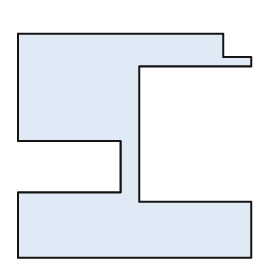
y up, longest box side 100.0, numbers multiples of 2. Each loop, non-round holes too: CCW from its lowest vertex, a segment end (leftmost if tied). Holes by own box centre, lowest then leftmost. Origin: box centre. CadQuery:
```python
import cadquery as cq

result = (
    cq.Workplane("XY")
    .moveTo(-50.0, -48.0)
    .lineTo(50.0, -48.0)
    .lineTo(50.0, -24.0)
    .lineTo(2.0, -24.0)
    .lineTo(2.0, 34.0)
    .lineTo(50.0, 34.0)
    .lineTo(50.0, 38.0)
    .lineTo(38.0, 38.0)
    .lineTo(38.0, 48.0)
    .lineTo(-50.0, 48.0)
    .lineTo(-50.0, 2.0)
    .lineTo(-6.0, 2.0)
    .lineTo(-6.0, -20.0)
    .lineTo(-50.0, -20.0)
    .close()
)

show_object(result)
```